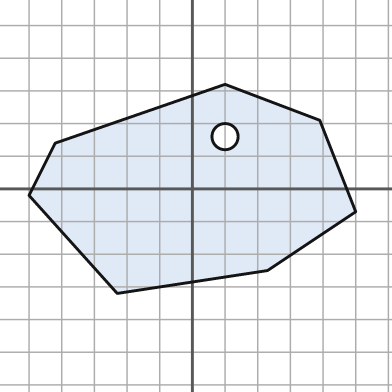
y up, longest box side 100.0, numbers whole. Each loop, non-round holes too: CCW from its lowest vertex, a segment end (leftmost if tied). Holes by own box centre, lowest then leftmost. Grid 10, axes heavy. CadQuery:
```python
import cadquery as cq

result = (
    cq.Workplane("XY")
    .moveTo(-23.0, -32.0)
    .lineTo(23.0, -25.0)
    .lineTo(50.0, -7.0)
    .lineTo(39.0, 21.0)
    .lineTo(10.0, 32.0)
    .lineTo(-42.0, 14.0)
    .lineTo(-50.0, -2.0)
    .close()
    .moveTo(10.0, 16.0)
    .circle(4.0)
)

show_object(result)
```